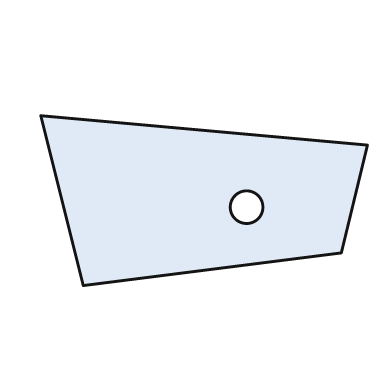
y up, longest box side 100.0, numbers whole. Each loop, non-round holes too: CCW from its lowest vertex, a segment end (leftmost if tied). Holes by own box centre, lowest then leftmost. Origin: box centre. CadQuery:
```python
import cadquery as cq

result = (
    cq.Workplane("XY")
    .moveTo(-37.0, -26.0)
    .lineTo(42.0, -16.0)
    .lineTo(50.0, 17.0)
    .lineTo(-50.0, 26.0)
    .close()
    .moveTo(13.0, -2.0)
    .circle(5.0)
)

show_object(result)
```